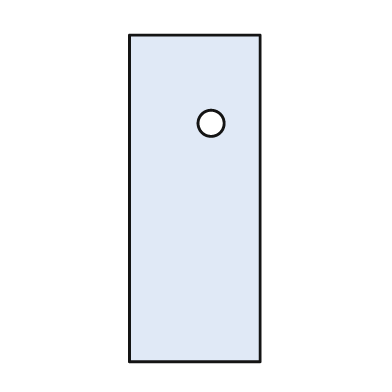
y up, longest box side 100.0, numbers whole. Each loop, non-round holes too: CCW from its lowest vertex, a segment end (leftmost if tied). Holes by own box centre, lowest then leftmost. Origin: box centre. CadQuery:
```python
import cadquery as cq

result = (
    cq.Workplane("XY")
    .moveTo(-20.0, -50.0)
    .lineTo(20.0, -50.0)
    .lineTo(20.0, 50.0)
    .lineTo(-20.0, 50.0)
    .close()
    .moveTo(5.0, 23.0)
    .circle(4.0)
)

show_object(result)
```